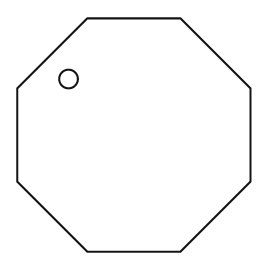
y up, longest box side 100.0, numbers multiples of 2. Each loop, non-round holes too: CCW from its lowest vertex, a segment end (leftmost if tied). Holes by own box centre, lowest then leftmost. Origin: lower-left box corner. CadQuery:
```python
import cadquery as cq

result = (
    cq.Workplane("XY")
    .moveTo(30.0, 0.0)
    .lineTo(70.0, 0.0)
    .lineTo(100.0, 30.0)
    .lineTo(100.0, 70.0)
    .lineTo(70.0, 100.0)
    .lineTo(30.0, 100.0)
    .lineTo(0.0, 70.0)
    .lineTo(0.0, 30.0)
    .close()
    .moveTo(22.0, 74.0)
    .circle(4.0)
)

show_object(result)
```